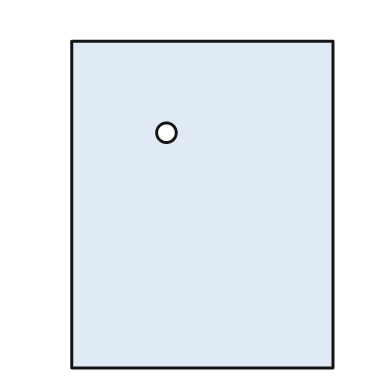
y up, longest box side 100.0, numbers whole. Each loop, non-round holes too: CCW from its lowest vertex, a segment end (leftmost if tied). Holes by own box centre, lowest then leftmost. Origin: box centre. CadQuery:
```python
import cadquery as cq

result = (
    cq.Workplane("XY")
    .moveTo(-40.0, -50.0)
    .lineTo(40.0, -50.0)
    .lineTo(40.0, 50.0)
    .lineTo(-40.0, 50.0)
    .close()
    .moveTo(-11.0, 22.0)
    .circle(3.0)
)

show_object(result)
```